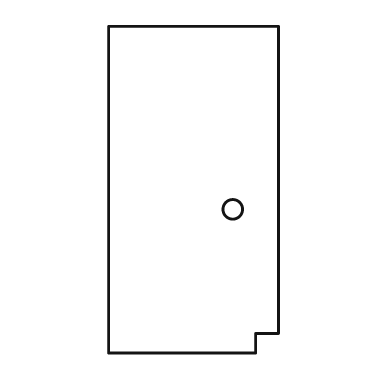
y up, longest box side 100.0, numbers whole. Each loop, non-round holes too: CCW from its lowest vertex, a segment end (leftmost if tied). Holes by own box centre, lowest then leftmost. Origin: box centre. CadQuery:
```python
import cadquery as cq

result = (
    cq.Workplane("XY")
    .moveTo(-26.0, -50.0)
    .lineTo(19.0, -50.0)
    .lineTo(19.0, -44.0)
    .lineTo(26.0, -44.0)
    .lineTo(26.0, 50.0)
    .lineTo(-26.0, 50.0)
    .close()
    .moveTo(12.0, -6.0)
    .circle(3.0)
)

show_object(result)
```